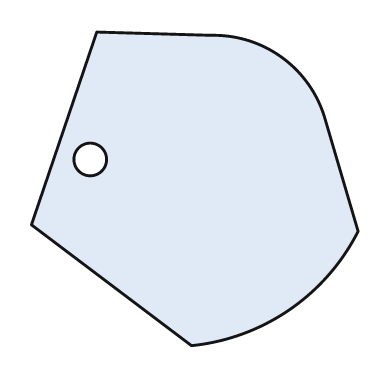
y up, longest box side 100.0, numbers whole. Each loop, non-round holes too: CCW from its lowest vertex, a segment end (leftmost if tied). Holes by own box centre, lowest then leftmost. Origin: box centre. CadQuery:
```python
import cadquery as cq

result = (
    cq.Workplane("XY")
    .moveTo(-1.0, -48.0)
    .threePointArc((29.0, -37.0), (50.0, -13.0))
    .lineTo(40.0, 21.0)
    .threePointArc((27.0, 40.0), (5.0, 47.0))
    .lineTo(-30.0, 48.0)
    .lineTo(-50.0, -11.0)
    .close()
    .moveTo(-32.0, 9.0)
    .circle(5.0)
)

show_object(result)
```